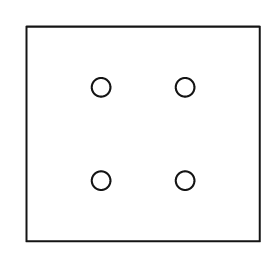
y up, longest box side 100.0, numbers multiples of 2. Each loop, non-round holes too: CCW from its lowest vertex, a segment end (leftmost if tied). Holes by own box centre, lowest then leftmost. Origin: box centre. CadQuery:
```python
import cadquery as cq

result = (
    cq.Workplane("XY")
    .moveTo(-50.0, -46.0)
    .lineTo(50.0, -46.0)
    .lineTo(50.0, 46.0)
    .lineTo(-50.0, 46.0)
    .close()
    .moveTo(-18.0, -20.0)
    .circle(4.0)
    .moveTo(18.0, -20.0)
    .circle(4.0)
    .moveTo(-18.0, 20.0)
    .circle(4.0)
    .moveTo(18.0, 20.0)
    .circle(4.0)
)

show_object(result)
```